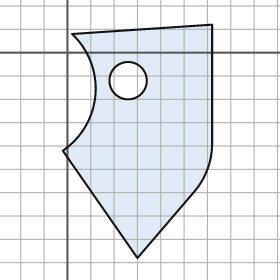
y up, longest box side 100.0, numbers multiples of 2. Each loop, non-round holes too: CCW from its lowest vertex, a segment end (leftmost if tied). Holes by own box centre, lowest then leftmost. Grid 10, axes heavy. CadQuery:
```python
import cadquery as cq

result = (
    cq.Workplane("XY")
    .moveTo(30.0, -88.0)
    .lineTo(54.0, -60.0)
    .threePointArc((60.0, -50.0), (62.0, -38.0))
    .lineTo(62.0, 12.0)
    .lineTo(2.0, 8.0)
    .threePointArc((12.0, -18.0), (-2.0, -42.0))
    .close()
    .moveTo(26.0, -12.0)
    .circle(8.0)
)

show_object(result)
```